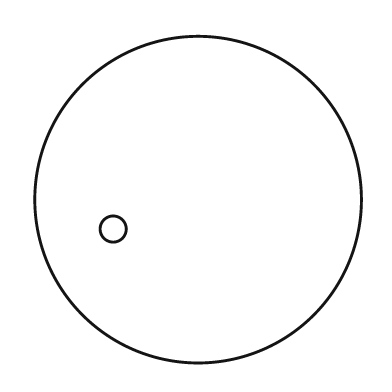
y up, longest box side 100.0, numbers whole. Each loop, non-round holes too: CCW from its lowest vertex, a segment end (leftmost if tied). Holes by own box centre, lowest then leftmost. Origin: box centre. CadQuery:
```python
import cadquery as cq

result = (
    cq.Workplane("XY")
    .moveTo(0.0, 0.0)
    .circle(50.0)
    .moveTo(-26.0, -9.0)
    .circle(4.0)
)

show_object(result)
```